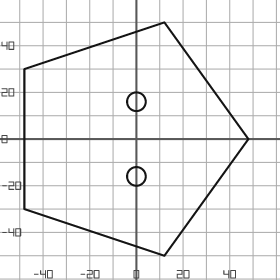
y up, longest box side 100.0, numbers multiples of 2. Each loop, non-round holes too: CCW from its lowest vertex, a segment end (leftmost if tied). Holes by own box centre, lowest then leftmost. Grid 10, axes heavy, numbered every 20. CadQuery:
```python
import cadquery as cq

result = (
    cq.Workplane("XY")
    .moveTo(12.0, -50.0)
    .lineTo(48.0, 0.0)
    .lineTo(12.0, 50.0)
    .lineTo(-48.0, 30.0)
    .lineTo(-48.0, -30.0)
    .close()
    .moveTo(0.0, -16.0)
    .circle(4.0)
    .moveTo(0.0, 16.0)
    .circle(4.0)
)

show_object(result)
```